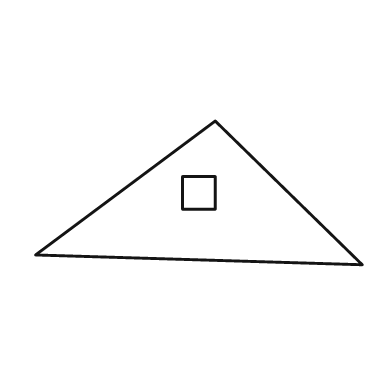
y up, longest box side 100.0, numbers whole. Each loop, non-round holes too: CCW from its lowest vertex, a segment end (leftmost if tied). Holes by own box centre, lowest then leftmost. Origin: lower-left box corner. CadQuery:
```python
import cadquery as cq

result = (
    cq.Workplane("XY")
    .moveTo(100.0, 0.0)
    .lineTo(55.0, 44.0)
    .lineTo(0.0, 3.0)
    .close()
    .moveTo(45.0, 17.0)
    .lineTo(55.0, 17.0)
    .lineTo(55.0, 27.0)
    .lineTo(45.0, 27.0)
    .close()
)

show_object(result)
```